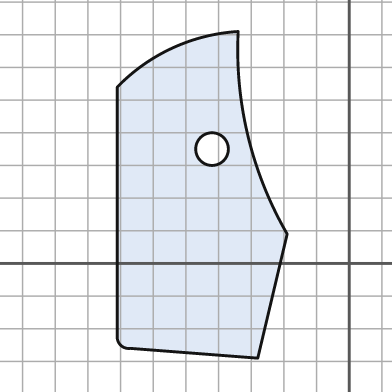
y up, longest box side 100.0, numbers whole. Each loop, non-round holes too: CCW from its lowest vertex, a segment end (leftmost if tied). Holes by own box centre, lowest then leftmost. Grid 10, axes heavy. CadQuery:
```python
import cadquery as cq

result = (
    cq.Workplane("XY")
    .moveTo(-28.0, -29.0)
    .lineTo(-19.0, 9.0)
    .threePointArc((-31.0, 39.0), (-34.0, 71.0))
    .threePointArc((-54.0, 66.0), (-71.0, 54.0))
    .lineTo(-71.0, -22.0)
    .threePointArc((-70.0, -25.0), (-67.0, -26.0))
    .close()
    .moveTo(-42.0, 35.0)
    .circle(5.0)
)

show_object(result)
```